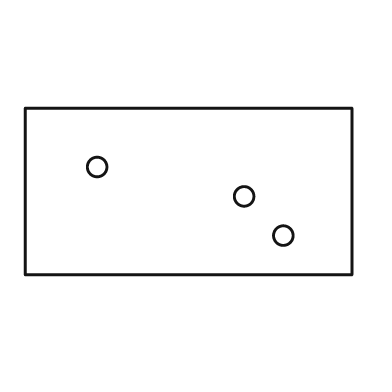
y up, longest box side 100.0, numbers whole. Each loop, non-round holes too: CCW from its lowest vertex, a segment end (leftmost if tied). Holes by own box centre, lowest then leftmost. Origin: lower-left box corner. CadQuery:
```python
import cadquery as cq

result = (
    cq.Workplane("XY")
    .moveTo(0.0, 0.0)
    .lineTo(100.0, 0.0)
    .lineTo(100.0, 51.0)
    .lineTo(0.0, 51.0)
    .close()
    .moveTo(79.0, 12.0)
    .circle(3.0)
    .moveTo(67.0, 24.0)
    .circle(3.0)
    .moveTo(22.0, 33.0)
    .circle(3.0)
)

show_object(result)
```